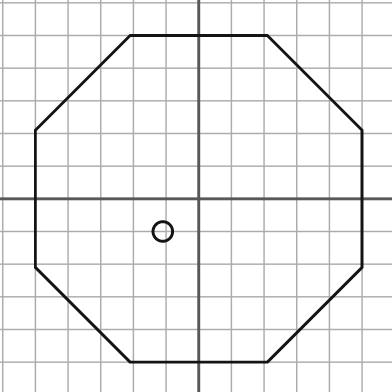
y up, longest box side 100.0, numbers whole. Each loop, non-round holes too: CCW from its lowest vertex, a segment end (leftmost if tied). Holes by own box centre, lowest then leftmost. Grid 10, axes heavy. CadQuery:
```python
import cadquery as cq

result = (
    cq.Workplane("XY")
    .moveTo(-21.0, -50.0)
    .lineTo(21.0, -50.0)
    .lineTo(50.0, -21.0)
    .lineTo(50.0, 21.0)
    .lineTo(21.0, 50.0)
    .lineTo(-21.0, 50.0)
    .lineTo(-50.0, 21.0)
    .lineTo(-50.0, -21.0)
    .close()
    .moveTo(-11.0, -10.0)
    .circle(3.0)
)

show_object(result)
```